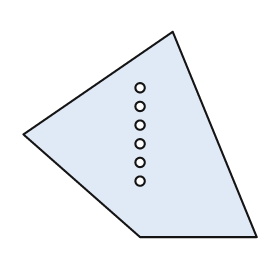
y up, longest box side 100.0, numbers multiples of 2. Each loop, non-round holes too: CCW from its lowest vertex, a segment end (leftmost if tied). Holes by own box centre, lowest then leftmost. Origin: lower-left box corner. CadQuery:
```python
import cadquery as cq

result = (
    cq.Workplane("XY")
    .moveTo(50.0, 0.0)
    .lineTo(100.0, 0.0)
    .lineTo(64.0, 88.0)
    .lineTo(0.0, 44.0)
    .close()
    .moveTo(50.0, 24.0)
    .circle(2.0)
    .moveTo(50.0, 32.0)
    .circle(2.0)
    .moveTo(50.0, 40.0)
    .circle(2.0)
    .moveTo(50.0, 48.0)
    .circle(2.0)
    .moveTo(50.0, 56.0)
    .circle(2.0)
    .moveTo(50.0, 64.0)
    .circle(2.0)
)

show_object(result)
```